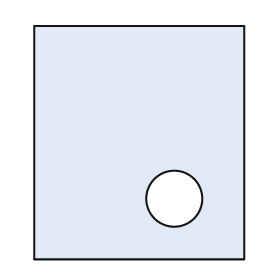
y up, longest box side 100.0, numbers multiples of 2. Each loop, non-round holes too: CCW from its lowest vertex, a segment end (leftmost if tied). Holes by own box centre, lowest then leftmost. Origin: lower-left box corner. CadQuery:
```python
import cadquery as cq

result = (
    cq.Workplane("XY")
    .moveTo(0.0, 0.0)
    .lineTo(90.0, 0.0)
    .lineTo(90.0, 100.0)
    .lineTo(0.0, 100.0)
    .close()
    .moveTo(60.0, 26.0)
    .circle(12.0)
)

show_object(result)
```